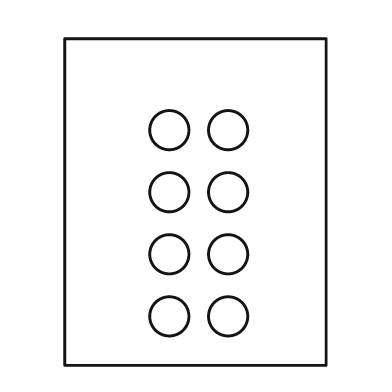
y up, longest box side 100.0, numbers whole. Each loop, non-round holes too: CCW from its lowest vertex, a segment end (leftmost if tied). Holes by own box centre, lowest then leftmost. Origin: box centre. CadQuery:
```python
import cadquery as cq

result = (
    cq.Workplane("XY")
    .moveTo(-40.0, -50.0)
    .lineTo(40.0, -50.0)
    .lineTo(40.0, 50.0)
    .lineTo(-40.0, 50.0)
    .close()
    .moveTo(-8.0, -35.0)
    .circle(6.0)
    .moveTo(10.0, -35.0)
    .circle(6.0)
    .moveTo(-8.0, -16.0)
    .circle(6.0)
    .moveTo(10.0, -16.0)
    .circle(6.0)
    .moveTo(-8.0, 3.0)
    .circle(6.0)
    .moveTo(10.0, 3.0)
    .circle(6.0)
    .moveTo(-8.0, 22.0)
    .circle(6.0)
    .moveTo(10.0, 22.0)
    .circle(6.0)
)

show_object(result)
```